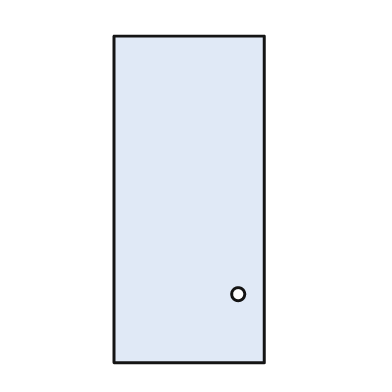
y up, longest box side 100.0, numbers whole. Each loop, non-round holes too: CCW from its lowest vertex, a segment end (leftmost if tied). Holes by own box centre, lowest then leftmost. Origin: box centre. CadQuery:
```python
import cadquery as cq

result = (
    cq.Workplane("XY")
    .moveTo(-23.0, -50.0)
    .lineTo(23.0, -50.0)
    .lineTo(23.0, 50.0)
    .lineTo(-23.0, 50.0)
    .close()
    .moveTo(15.0, -29.0)
    .circle(2.0)
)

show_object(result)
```